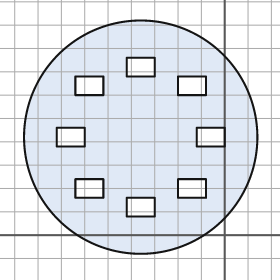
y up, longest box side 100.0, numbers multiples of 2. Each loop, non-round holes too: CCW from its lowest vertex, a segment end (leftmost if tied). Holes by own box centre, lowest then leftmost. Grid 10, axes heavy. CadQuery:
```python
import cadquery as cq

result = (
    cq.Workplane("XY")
    .moveTo(-36.0, 42.0)
    .circle(50.0)
    .moveTo(-42.0, 8.0)
    .lineTo(-30.0, 8.0)
    .lineTo(-30.0, 16.0)
    .lineTo(-42.0, 16.0)
    .close()
    .moveTo(-64.0, 16.0)
    .lineTo(-52.0, 16.0)
    .lineTo(-52.0, 24.0)
    .lineTo(-64.0, 24.0)
    .close()
    .moveTo(-20.0, 16.0)
    .lineTo(-8.0, 16.0)
    .lineTo(-8.0, 24.0)
    .lineTo(-20.0, 24.0)
    .close()
    .moveTo(-72.0, 38.0)
    .lineTo(-60.0, 38.0)
    .lineTo(-60.0, 46.0)
    .lineTo(-72.0, 46.0)
    .close()
    .moveTo(-12.0, 38.0)
    .lineTo(0.0, 38.0)
    .lineTo(0.0, 46.0)
    .lineTo(-12.0, 46.0)
    .close()
    .moveTo(-64.0, 60.0)
    .lineTo(-52.0, 60.0)
    .lineTo(-52.0, 68.0)
    .lineTo(-64.0, 68.0)
    .close()
    .moveTo(-20.0, 60.0)
    .lineTo(-8.0, 60.0)
    .lineTo(-8.0, 68.0)
    .lineTo(-20.0, 68.0)
    .close()
    .moveTo(-42.0, 68.0)
    .lineTo(-30.0, 68.0)
    .lineTo(-30.0, 76.0)
    .lineTo(-42.0, 76.0)
    .close()
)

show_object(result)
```